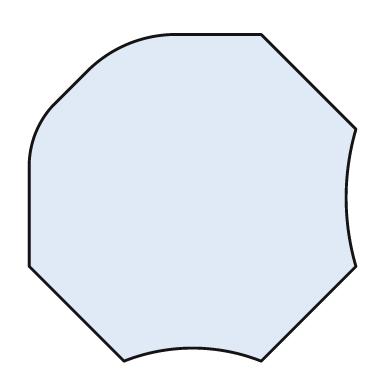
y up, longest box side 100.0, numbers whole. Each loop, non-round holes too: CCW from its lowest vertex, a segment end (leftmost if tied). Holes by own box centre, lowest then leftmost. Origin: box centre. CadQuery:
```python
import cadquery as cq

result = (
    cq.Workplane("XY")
    .moveTo(-21.0, -50.0)
    .threePointArc((0.0, -46.0), (21.0, -50.0))
    .lineTo(50.0, -21.0)
    .threePointArc((47.0, 0.0), (50.0, 21.0))
    .lineTo(21.0, 50.0)
    .lineTo(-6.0, 50.0)
    .threePointArc((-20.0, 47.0), (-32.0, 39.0))
    .lineTo(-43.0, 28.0)
    .threePointArc((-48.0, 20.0), (-50.0, 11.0))
    .lineTo(-50.0, -21.0)
    .close()
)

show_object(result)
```